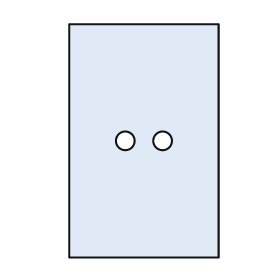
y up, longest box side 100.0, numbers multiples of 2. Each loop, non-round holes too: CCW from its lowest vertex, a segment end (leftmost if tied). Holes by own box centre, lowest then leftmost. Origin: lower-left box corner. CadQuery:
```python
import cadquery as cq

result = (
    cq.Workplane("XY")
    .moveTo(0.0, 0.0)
    .lineTo(64.0, 0.0)
    .lineTo(64.0, 100.0)
    .lineTo(0.0, 100.0)
    .close()
    .moveTo(24.0, 50.0)
    .circle(4.0)
    .moveTo(40.0, 50.0)
    .circle(4.0)
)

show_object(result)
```